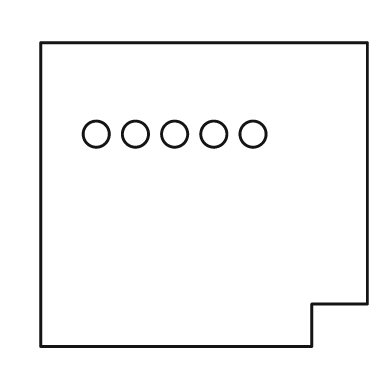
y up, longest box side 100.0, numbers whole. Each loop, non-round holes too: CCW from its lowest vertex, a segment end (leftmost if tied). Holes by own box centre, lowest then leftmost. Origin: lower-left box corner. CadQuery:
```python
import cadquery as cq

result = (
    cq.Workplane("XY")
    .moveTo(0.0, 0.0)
    .lineTo(83.0, 0.0)
    .lineTo(83.0, 13.0)
    .lineTo(100.0, 13.0)
    .lineTo(100.0, 93.0)
    .lineTo(0.0, 93.0)
    .close()
    .moveTo(17.0, 65.0)
    .circle(4.0)
    .moveTo(29.0, 65.0)
    .circle(4.0)
    .moveTo(41.0, 65.0)
    .circle(4.0)
    .moveTo(53.0, 65.0)
    .circle(4.0)
    .moveTo(65.0, 65.0)
    .circle(4.0)
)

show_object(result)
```